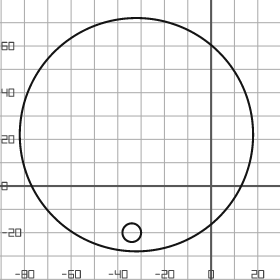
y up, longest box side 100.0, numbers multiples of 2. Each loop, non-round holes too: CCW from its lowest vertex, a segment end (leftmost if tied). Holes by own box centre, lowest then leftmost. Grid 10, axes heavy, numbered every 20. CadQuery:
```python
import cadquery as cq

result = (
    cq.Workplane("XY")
    .moveTo(-32.0, 22.0)
    .circle(50.0)
    .moveTo(-34.0, -20.0)
    .circle(4.0)
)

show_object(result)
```